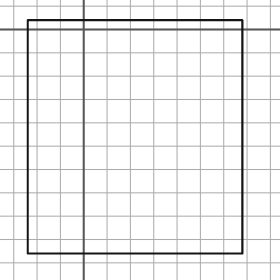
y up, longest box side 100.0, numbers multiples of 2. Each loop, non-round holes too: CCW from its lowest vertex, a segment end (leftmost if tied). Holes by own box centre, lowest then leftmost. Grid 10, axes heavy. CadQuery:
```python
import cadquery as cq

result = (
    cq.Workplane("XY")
    .moveTo(-24.0, -96.0)
    .lineTo(68.0, -96.0)
    .lineTo(68.0, 4.0)
    .lineTo(-24.0, 4.0)
    .close()
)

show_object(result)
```